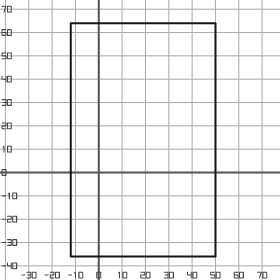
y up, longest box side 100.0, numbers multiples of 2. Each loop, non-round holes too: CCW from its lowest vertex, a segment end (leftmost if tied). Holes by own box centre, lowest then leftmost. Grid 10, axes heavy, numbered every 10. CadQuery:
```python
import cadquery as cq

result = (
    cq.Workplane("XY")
    .moveTo(-12.0, -36.0)
    .lineTo(50.0, -36.0)
    .lineTo(50.0, 64.0)
    .lineTo(-12.0, 64.0)
    .close()
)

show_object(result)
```